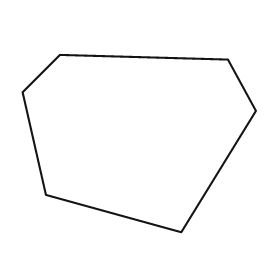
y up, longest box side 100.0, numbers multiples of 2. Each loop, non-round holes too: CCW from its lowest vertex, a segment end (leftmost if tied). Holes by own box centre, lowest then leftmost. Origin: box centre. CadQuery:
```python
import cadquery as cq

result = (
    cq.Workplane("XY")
    .moveTo(18.0, -38.0)
    .lineTo(50.0, 14.0)
    .lineTo(38.0, 36.0)
    .lineTo(-34.0, 38.0)
    .lineTo(-50.0, 22.0)
    .lineTo(-40.0, -22.0)
    .close()
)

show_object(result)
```